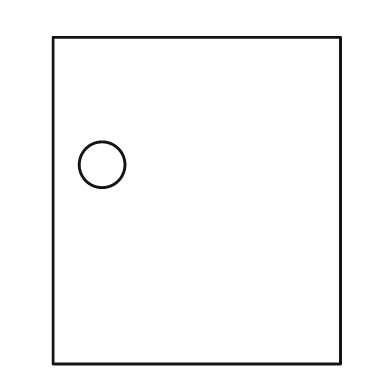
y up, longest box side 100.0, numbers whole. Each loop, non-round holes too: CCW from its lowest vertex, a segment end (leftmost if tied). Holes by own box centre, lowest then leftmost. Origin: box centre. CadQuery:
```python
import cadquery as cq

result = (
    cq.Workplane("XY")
    .moveTo(-44.0, -50.0)
    .lineTo(44.0, -50.0)
    .lineTo(44.0, 50.0)
    .lineTo(-44.0, 50.0)
    .close()
    .moveTo(-29.0, 11.0)
    .circle(7.0)
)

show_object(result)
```